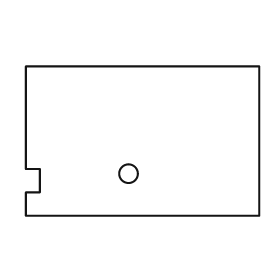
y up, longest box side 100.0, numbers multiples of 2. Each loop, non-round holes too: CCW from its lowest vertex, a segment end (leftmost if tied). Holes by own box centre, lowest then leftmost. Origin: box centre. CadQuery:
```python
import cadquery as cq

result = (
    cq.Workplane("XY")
    .moveTo(-50.0, -32.0)
    .lineTo(50.0, -32.0)
    .lineTo(50.0, 32.0)
    .lineTo(-50.0, 32.0)
    .lineTo(-50.0, -12.0)
    .lineTo(-44.0, -12.0)
    .lineTo(-44.0, -22.0)
    .lineTo(-50.0, -22.0)
    .close()
    .moveTo(-6.0, -14.0)
    .circle(4.0)
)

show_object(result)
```